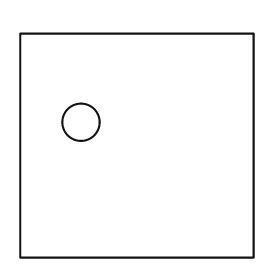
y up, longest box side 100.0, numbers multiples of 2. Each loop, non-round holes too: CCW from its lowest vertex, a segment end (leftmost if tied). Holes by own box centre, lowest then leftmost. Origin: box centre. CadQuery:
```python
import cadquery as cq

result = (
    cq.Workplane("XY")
    .moveTo(-50.0, -48.0)
    .lineTo(50.0, -48.0)
    .lineTo(50.0, 48.0)
    .lineTo(-50.0, 48.0)
    .close()
    .moveTo(-24.0, 10.0)
    .circle(8.0)
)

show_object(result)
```